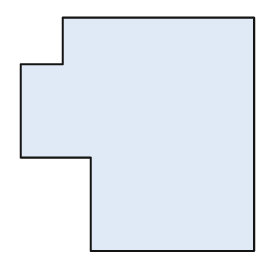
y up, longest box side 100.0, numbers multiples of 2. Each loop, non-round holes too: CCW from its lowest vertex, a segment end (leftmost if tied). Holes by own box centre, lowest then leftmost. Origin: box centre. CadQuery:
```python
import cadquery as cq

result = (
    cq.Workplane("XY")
    .moveTo(-20.0, -50.0)
    .lineTo(50.0, -50.0)
    .lineTo(50.0, 50.0)
    .lineTo(-32.0, 50.0)
    .lineTo(-32.0, 30.0)
    .lineTo(-50.0, 30.0)
    .lineTo(-50.0, -10.0)
    .lineTo(-20.0, -10.0)
    .close()
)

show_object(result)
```